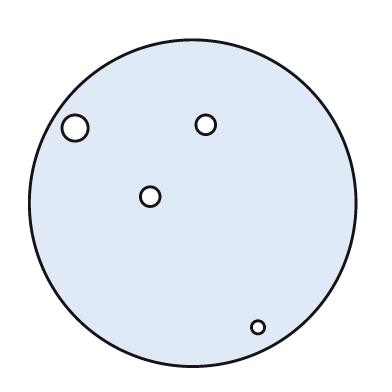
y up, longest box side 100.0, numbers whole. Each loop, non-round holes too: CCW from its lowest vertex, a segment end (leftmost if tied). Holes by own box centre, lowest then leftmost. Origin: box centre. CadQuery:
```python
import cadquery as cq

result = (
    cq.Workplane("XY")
    .moveTo(0.0, 0.0)
    .circle(50.0)
    .moveTo(20.0, -38.0)
    .circle(2.0)
    .moveTo(-13.0, 2.0)
    .circle(3.0)
    .moveTo(-36.0, 23.0)
    .circle(4.0)
    .moveTo(4.0, 24.0)
    .circle(3.0)
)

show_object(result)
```